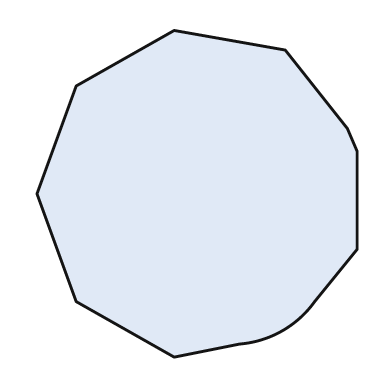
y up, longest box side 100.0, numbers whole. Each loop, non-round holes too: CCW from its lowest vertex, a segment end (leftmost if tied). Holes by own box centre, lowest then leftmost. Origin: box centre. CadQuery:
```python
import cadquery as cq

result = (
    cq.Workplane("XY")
    .moveTo(-7.0, -50.0)
    .lineTo(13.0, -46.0)
    .threePointArc((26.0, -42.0), (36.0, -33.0))
    .lineTo(49.0, -17.0)
    .lineTo(49.0, 13.0)
    .lineTo(46.0, 20.0)
    .lineTo(27.0, 44.0)
    .lineTo(-7.0, 50.0)
    .lineTo(-37.0, 33.0)
    .lineTo(-49.0, 0.0)
    .lineTo(-37.0, -33.0)
    .close()
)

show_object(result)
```